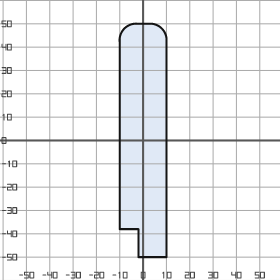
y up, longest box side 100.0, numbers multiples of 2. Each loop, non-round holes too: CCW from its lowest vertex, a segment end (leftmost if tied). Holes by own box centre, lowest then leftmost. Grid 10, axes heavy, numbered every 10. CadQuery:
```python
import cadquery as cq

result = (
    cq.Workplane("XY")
    .moveTo(-2.0, -50.0)
    .lineTo(10.0, -50.0)
    .lineTo(10.0, 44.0)
    .threePointArc((8.0, 48.0), (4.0, 50.0))
    .lineTo(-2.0, 50.0)
    .threePointArc((-8.0, 48.0), (-10.0, 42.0))
    .lineTo(-10.0, -38.0)
    .lineTo(-2.0, -38.0)
    .close()
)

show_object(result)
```